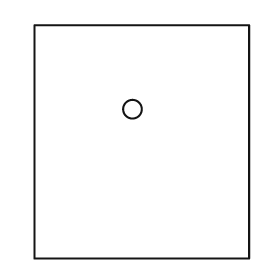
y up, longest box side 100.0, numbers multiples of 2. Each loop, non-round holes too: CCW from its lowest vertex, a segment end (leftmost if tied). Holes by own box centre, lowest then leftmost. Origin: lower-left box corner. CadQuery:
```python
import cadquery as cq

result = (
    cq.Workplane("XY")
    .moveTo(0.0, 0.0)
    .lineTo(92.0, 0.0)
    .lineTo(92.0, 100.0)
    .lineTo(0.0, 100.0)
    .close()
    .moveTo(42.0, 64.0)
    .circle(4.0)
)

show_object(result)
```